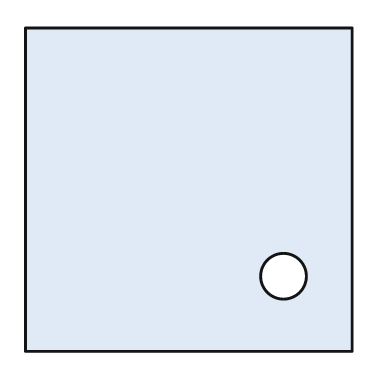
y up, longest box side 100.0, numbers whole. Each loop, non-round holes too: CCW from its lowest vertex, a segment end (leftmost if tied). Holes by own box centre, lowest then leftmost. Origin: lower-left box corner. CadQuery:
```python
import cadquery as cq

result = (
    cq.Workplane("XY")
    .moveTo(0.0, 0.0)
    .lineTo(100.0, 0.0)
    .lineTo(100.0, 99.0)
    .lineTo(0.0, 99.0)
    .close()
    .moveTo(79.0, 23.0)
    .circle(7.0)
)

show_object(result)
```